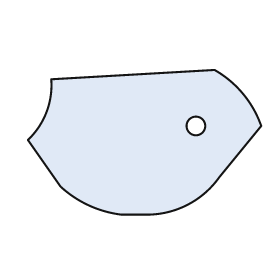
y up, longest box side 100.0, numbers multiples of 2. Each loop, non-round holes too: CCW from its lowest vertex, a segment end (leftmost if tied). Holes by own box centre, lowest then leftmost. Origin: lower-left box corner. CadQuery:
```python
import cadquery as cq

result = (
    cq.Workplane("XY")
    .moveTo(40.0, 0.0)
    .lineTo(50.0, 0.0)
    .threePointArc((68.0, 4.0), (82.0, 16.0))
    .lineTo(100.0, 38.0)
    .threePointArc((92.0, 52.0), (80.0, 62.0))
    .lineTo(10.0, 58.0)
    .threePointArc((8.0, 44.0), (0.0, 32.0))
    .lineTo(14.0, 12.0)
    .threePointArc((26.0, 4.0), (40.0, 0.0))
    .close()
    .moveTo(72.0, 38.0)
    .circle(4.0)
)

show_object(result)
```